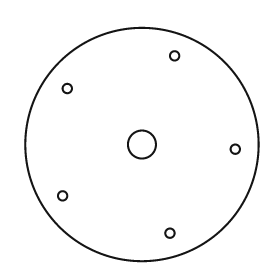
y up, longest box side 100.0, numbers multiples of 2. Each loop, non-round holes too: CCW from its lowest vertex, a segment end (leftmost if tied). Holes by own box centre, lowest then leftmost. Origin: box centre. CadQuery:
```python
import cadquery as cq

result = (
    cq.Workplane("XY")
    .moveTo(0.0, 0.0)
    .circle(50.0)
    .moveTo(12.0, -38.0)
    .circle(2.0)
    .moveTo(-34.0, -22.0)
    .circle(2.0)
    .moveTo(40.0, -2.0)
    .circle(2.0)
    .moveTo(0.0, 0.0)
    .circle(6.0)
    .moveTo(-32.0, 24.0)
    .circle(2.0)
    .moveTo(14.0, 38.0)
    .circle(2.0)
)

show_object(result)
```